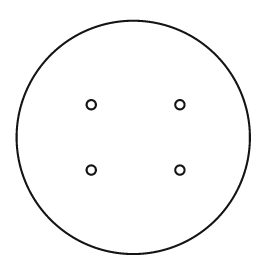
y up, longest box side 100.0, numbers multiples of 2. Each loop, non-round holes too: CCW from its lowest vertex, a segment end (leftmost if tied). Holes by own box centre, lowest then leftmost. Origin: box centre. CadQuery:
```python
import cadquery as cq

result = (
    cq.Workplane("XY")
    .moveTo(0.0, 0.0)
    .circle(50.0)
    .moveTo(-18.0, -14.0)
    .circle(2.0)
    .moveTo(20.0, -14.0)
    .circle(2.0)
    .moveTo(-18.0, 14.0)
    .circle(2.0)
    .moveTo(20.0, 14.0)
    .circle(2.0)
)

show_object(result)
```